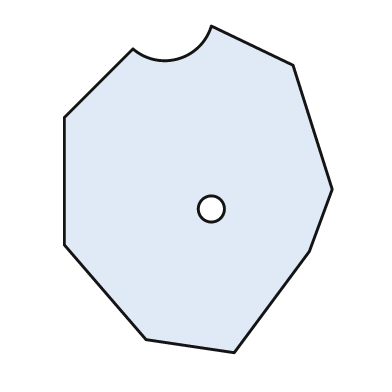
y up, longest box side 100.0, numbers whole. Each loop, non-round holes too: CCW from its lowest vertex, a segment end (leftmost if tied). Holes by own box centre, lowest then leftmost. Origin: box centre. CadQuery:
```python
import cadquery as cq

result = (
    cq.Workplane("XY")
    .moveTo(11.0, -50.0)
    .lineTo(34.0, -19.0)
    .lineTo(41.0, 0.0)
    .lineTo(29.0, 38.0)
    .lineTo(4.0, 50.0)
    .threePointArc((-6.0, 40.0), (-20.0, 43.0))
    .lineTo(-41.0, 22.0)
    .lineTo(-41.0, -17.0)
    .lineTo(-16.0, -46.0)
    .close()
    .moveTo(4.0, -6.0)
    .circle(4.0)
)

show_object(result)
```